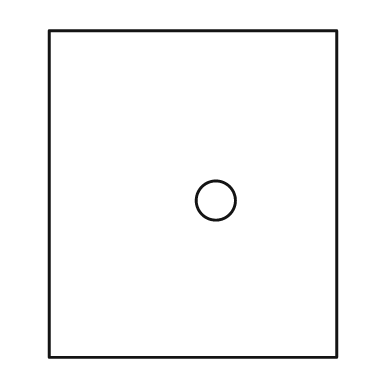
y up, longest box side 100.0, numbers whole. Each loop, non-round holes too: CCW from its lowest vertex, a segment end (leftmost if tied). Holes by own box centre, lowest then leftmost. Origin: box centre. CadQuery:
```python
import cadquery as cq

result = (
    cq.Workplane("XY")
    .moveTo(-44.0, -50.0)
    .lineTo(44.0, -50.0)
    .lineTo(44.0, 50.0)
    .lineTo(-44.0, 50.0)
    .close()
    .moveTo(7.0, -2.0)
    .circle(6.0)
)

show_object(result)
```